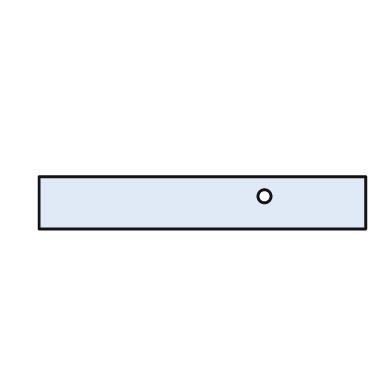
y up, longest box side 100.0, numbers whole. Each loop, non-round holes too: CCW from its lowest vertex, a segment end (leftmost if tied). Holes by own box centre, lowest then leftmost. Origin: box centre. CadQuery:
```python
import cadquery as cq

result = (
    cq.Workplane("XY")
    .moveTo(-50.0, -8.0)
    .lineTo(50.0, -8.0)
    .lineTo(50.0, 8.0)
    .lineTo(-50.0, 8.0)
    .close()
    .moveTo(19.0, 2.0)
    .circle(2.0)
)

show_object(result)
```